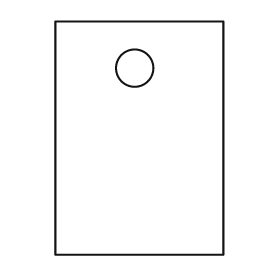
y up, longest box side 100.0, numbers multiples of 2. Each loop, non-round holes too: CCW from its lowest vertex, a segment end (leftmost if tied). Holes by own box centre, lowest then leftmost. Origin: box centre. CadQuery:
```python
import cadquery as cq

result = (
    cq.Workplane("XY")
    .moveTo(-36.0, -50.0)
    .lineTo(36.0, -50.0)
    .lineTo(36.0, 50.0)
    .lineTo(-36.0, 50.0)
    .close()
    .moveTo(-2.0, 30.0)
    .circle(8.0)
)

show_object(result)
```